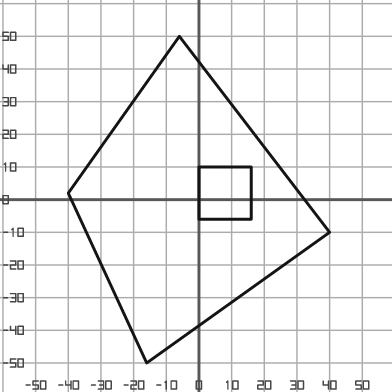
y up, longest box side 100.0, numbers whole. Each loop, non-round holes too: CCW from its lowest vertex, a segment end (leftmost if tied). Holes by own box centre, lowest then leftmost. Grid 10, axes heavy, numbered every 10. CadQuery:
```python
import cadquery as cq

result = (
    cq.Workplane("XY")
    .moveTo(-16.0, -50.0)
    .lineTo(40.0, -10.0)
    .lineTo(-6.0, 50.0)
    .lineTo(-40.0, 2.0)
    .close()
    .moveTo(0.0, -6.0)
    .lineTo(16.0, -6.0)
    .lineTo(16.0, 10.0)
    .lineTo(0.0, 10.0)
    .close()
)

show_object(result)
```